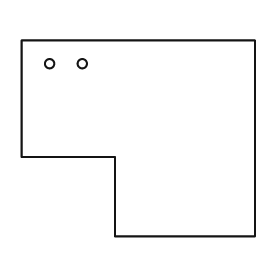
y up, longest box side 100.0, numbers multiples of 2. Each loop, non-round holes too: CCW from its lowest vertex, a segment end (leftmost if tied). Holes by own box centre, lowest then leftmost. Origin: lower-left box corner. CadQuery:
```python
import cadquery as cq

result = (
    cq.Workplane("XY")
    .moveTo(40.0, 0.0)
    .lineTo(100.0, 0.0)
    .lineTo(100.0, 84.0)
    .lineTo(0.0, 84.0)
    .lineTo(0.0, 34.0)
    .lineTo(40.0, 34.0)
    .close()
    .moveTo(12.0, 74.0)
    .circle(2.0)
    .moveTo(26.0, 74.0)
    .circle(2.0)
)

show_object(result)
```